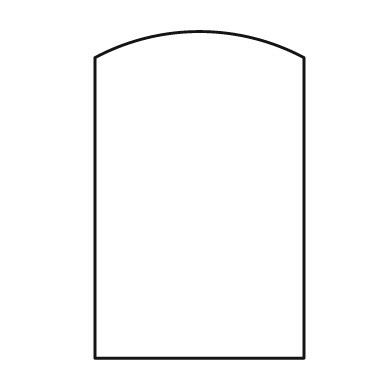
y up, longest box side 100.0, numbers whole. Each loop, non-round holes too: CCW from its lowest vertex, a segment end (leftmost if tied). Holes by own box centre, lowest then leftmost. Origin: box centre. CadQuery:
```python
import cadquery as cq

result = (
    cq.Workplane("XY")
    .moveTo(-32.0, -50.0)
    .lineTo(32.0, -50.0)
    .lineTo(32.0, 42.0)
    .threePointArc((0.0, 50.0), (-32.0, 42.0))
    .close()
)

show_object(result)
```